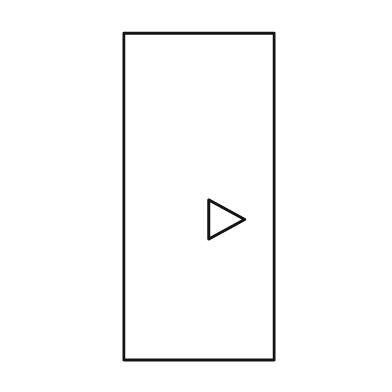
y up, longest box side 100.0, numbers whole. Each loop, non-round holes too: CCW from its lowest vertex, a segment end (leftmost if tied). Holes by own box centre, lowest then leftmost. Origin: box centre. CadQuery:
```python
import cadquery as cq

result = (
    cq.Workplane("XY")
    .moveTo(-23.0, -50.0)
    .lineTo(23.0, -50.0)
    .lineTo(23.0, 50.0)
    .lineTo(-23.0, 50.0)
    .close()
    .moveTo(3.0, -13.0)
    .lineTo(14.0, -7.0)
    .lineTo(3.0, -1.0)
    .close()
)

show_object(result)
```